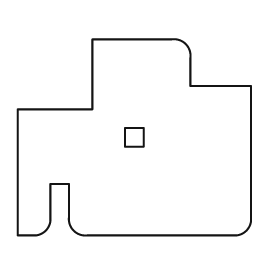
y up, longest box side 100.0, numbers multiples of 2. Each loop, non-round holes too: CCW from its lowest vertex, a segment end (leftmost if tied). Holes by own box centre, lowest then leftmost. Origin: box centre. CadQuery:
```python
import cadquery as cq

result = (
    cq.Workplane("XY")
    .moveTo(-50.0, -42.0)
    .lineTo(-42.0, -42.0)
    .threePointArc((-38.0, -40.0), (-36.0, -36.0))
    .lineTo(-36.0, -20.0)
    .lineTo(-28.0, -20.0)
    .lineTo(-28.0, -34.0)
    .threePointArc((-26.0, -40.0), (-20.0, -42.0))
    .lineTo(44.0, -42.0)
    .threePointArc((48.0, -40.0), (50.0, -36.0))
    .lineTo(50.0, 22.0)
    .lineTo(24.0, 22.0)
    .lineTo(24.0, 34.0)
    .threePointArc((22.0, 40.0), (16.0, 42.0))
    .lineTo(-18.0, 42.0)
    .lineTo(-18.0, 12.0)
    .lineTo(-50.0, 12.0)
    .close()
    .moveTo(-4.0, -4.0)
    .lineTo(4.0, -4.0)
    .lineTo(4.0, 4.0)
    .lineTo(-4.0, 4.0)
    .close()
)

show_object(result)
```